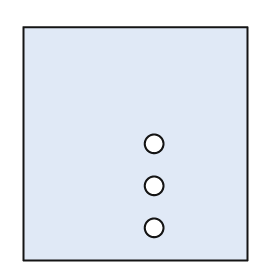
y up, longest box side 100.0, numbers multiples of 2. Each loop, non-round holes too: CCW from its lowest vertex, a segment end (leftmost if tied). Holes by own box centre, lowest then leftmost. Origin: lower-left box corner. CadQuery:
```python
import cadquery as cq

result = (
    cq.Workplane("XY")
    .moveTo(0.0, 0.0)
    .lineTo(96.0, 0.0)
    .lineTo(96.0, 100.0)
    .lineTo(0.0, 100.0)
    .close()
    .moveTo(56.0, 14.0)
    .circle(4.0)
    .moveTo(56.0, 32.0)
    .circle(4.0)
    .moveTo(56.0, 50.0)
    .circle(4.0)
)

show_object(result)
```